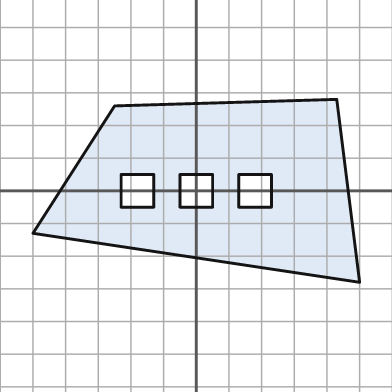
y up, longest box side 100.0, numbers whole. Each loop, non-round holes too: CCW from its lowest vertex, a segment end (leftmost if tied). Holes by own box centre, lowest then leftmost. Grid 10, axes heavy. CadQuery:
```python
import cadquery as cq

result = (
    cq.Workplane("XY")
    .moveTo(50.0, -28.0)
    .lineTo(43.0, 28.0)
    .lineTo(-25.0, 26.0)
    .lineTo(-50.0, -13.0)
    .close()
    .moveTo(-23.0, -5.0)
    .lineTo(-13.0, -5.0)
    .lineTo(-13.0, 5.0)
    .lineTo(-23.0, 5.0)
    .close()
    .moveTo(-5.0, -5.0)
    .lineTo(5.0, -5.0)
    .lineTo(5.0, 5.0)
    .lineTo(-5.0, 5.0)
    .close()
    .moveTo(13.0, -5.0)
    .lineTo(23.0, -5.0)
    .lineTo(23.0, 5.0)
    .lineTo(13.0, 5.0)
    .close()
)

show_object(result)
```